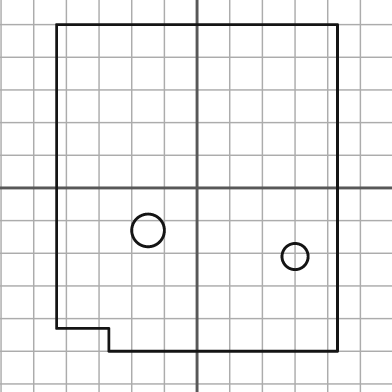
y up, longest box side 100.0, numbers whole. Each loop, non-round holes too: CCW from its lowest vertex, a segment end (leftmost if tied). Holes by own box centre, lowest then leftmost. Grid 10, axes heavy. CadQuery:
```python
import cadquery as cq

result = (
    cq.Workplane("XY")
    .moveTo(-27.0, -50.0)
    .lineTo(43.0, -50.0)
    .lineTo(43.0, 50.0)
    .lineTo(-43.0, 50.0)
    .lineTo(-43.0, -43.0)
    .lineTo(-27.0, -43.0)
    .close()
    .moveTo(30.0, -21.0)
    .circle(4.0)
    .moveTo(-15.0, -13.0)
    .circle(5.0)
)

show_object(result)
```